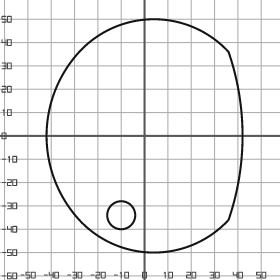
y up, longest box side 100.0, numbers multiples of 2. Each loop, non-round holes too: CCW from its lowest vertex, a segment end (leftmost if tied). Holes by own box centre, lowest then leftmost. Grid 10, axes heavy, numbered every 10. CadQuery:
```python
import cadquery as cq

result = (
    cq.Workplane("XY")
    .moveTo(-28.0, -36.0)
    .threePointArc((4.0, -50.0), (36.0, -36.0))
    .threePointArc((42.0, 0.0), (36.0, 36.0))
    .threePointArc((4.0, 50.0), (-28.0, 36.0))
    .threePointArc((-42.0, 0.0), (-28.0, -36.0))
    .close()
    .moveTo(-10.0, -34.0)
    .circle(6.0)
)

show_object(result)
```